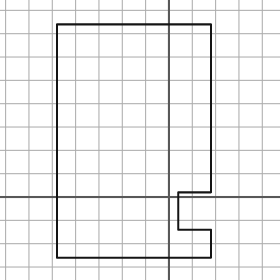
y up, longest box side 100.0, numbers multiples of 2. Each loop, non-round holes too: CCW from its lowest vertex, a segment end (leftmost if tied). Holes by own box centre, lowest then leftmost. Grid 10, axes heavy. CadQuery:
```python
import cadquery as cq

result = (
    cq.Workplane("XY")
    .moveTo(-48.0, -26.0)
    .lineTo(18.0, -26.0)
    .lineTo(18.0, -14.0)
    .lineTo(4.0, -14.0)
    .lineTo(4.0, 2.0)
    .lineTo(18.0, 2.0)
    .lineTo(18.0, 74.0)
    .lineTo(-48.0, 74.0)
    .close()
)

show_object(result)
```